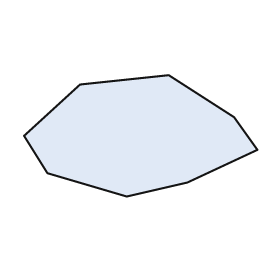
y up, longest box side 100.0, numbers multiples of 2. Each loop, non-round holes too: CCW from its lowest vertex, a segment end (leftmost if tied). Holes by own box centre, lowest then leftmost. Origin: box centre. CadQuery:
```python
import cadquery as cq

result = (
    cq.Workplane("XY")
    .moveTo(-6.0, -26.0)
    .lineTo(20.0, -20.0)
    .lineTo(50.0, -6.0)
    .lineTo(40.0, 8.0)
    .lineTo(12.0, 26.0)
    .lineTo(-26.0, 22.0)
    .lineTo(-50.0, 0.0)
    .lineTo(-40.0, -16.0)
    .close()
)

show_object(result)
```